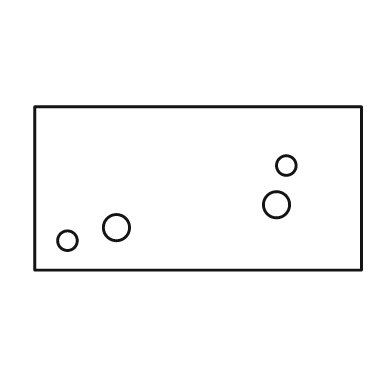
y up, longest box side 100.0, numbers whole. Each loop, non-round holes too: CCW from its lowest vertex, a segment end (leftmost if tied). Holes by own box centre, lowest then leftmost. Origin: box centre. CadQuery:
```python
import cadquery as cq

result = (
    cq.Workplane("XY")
    .moveTo(-50.0, -25.0)
    .lineTo(50.0, -25.0)
    .lineTo(50.0, 25.0)
    .lineTo(-50.0, 25.0)
    .close()
    .moveTo(-40.0, -16.0)
    .circle(3.0)
    .moveTo(-25.0, -12.0)
    .circle(4.0)
    .moveTo(24.0, -5.0)
    .circle(4.0)
    .moveTo(27.0, 7.0)
    .circle(3.0)
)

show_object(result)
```